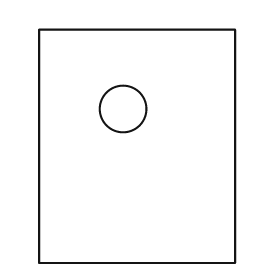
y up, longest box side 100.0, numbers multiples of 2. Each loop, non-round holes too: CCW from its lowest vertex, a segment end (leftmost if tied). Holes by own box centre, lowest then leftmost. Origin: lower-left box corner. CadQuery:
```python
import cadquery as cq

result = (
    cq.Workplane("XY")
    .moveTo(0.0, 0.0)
    .lineTo(84.0, 0.0)
    .lineTo(84.0, 100.0)
    .lineTo(0.0, 100.0)
    .close()
    .moveTo(36.0, 66.0)
    .circle(10.0)
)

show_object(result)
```